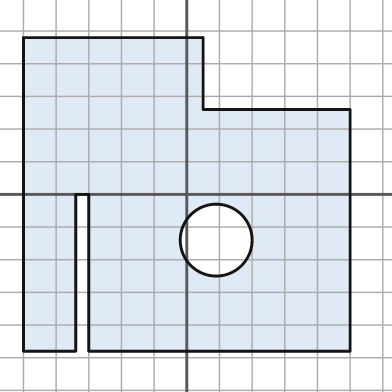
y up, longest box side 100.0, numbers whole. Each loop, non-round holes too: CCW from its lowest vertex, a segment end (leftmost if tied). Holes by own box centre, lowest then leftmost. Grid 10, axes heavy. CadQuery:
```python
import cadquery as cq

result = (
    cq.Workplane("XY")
    .moveTo(-50.0, -48.0)
    .lineTo(-34.0, -48.0)
    .lineTo(-34.0, 0.0)
    .lineTo(-30.0, 0.0)
    .lineTo(-30.0, -48.0)
    .lineTo(50.0, -48.0)
    .lineTo(50.0, 26.0)
    .lineTo(5.0, 26.0)
    .lineTo(5.0, 48.0)
    .lineTo(-50.0, 48.0)
    .close()
    .moveTo(9.0, -14.0)
    .circle(11.0)
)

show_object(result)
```